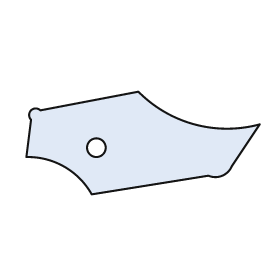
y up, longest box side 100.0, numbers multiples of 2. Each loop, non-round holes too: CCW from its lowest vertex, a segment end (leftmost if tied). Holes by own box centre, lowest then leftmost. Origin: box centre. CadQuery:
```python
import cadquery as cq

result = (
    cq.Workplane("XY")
    .moveTo(-22.0, -22.0)
    .lineTo(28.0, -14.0)
    .threePointArc((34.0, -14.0), (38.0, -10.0))
    .lineTo(50.0, 8.0)
    .threePointArc((22.0, 8.0), (-2.0, 22.0))
    .lineTo(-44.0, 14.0)
    .threePointArc((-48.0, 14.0), (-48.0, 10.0))
    .lineTo(-50.0, -6.0)
    .threePointArc((-34.0, -10.0), (-22.0, -22.0))
    .close()
    .moveTo(-20.0, -2.0)
    .circle(4.0)
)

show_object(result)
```